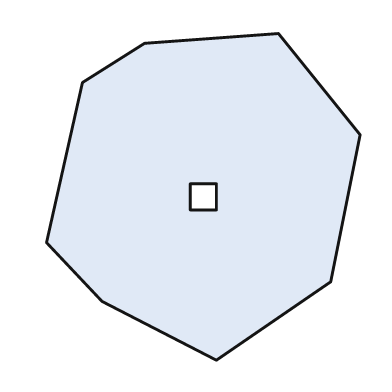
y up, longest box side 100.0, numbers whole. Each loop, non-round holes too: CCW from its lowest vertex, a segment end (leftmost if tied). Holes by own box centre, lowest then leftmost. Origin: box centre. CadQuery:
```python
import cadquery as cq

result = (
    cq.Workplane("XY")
    .moveTo(4.0, -50.0)
    .lineTo(39.0, -26.0)
    .lineTo(48.0, 19.0)
    .lineTo(23.0, 50.0)
    .lineTo(-18.0, 47.0)
    .lineTo(-37.0, 35.0)
    .lineTo(-48.0, -14.0)
    .lineTo(-31.0, -32.0)
    .close()
    .moveTo(-4.0, -4.0)
    .lineTo(4.0, -4.0)
    .lineTo(4.0, 4.0)
    .lineTo(-4.0, 4.0)
    .close()
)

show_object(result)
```